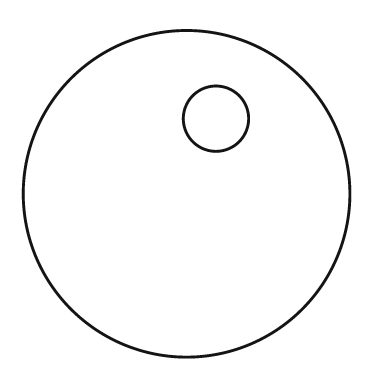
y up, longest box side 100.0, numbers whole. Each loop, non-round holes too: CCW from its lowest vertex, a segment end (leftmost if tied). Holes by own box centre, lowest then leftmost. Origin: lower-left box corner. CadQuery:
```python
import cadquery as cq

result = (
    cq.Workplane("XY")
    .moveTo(50.0, 50.0)
    .circle(50.0)
    .moveTo(59.0, 73.0)
    .circle(10.0)
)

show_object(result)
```